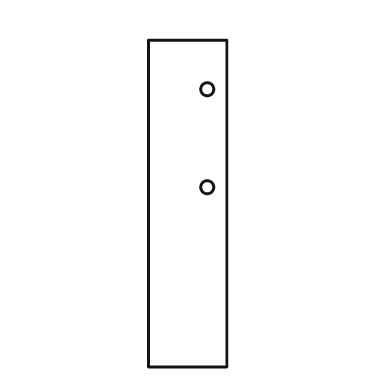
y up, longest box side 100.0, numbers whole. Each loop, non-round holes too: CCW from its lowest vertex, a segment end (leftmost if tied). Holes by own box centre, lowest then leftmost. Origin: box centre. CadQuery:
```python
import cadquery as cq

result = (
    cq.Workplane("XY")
    .moveTo(-12.0, -50.0)
    .lineTo(12.0, -50.0)
    .lineTo(12.0, 50.0)
    .lineTo(-12.0, 50.0)
    .close()
    .moveTo(6.0, 5.0)
    .circle(2.0)
    .moveTo(6.0, 35.0)
    .circle(2.0)
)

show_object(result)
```